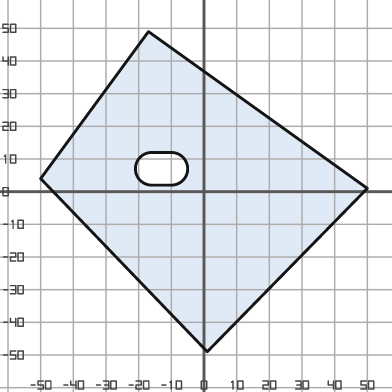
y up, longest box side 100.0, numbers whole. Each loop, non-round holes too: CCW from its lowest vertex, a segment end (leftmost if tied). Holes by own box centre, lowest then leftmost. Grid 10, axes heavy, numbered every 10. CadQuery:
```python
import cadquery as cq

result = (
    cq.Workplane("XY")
    .moveTo(1.0, -49.0)
    .lineTo(50.0, 1.0)
    .lineTo(-17.0, 49.0)
    .lineTo(-50.0, 4.0)
    .close()
    .moveTo(-16.0, 2.0)
    .lineTo(-10.0, 2.0)
    .threePointArc((-5.0, 7.0), (-10.0, 12.0))
    .lineTo(-16.0, 12.0)
    .threePointArc((-21.0, 7.0), (-16.0, 2.0))
    .close()
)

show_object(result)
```